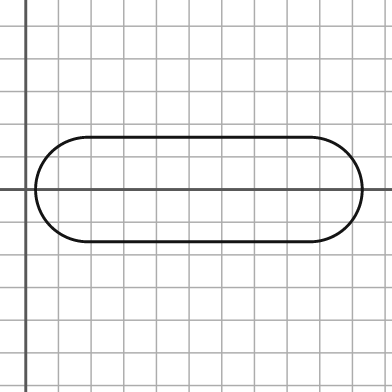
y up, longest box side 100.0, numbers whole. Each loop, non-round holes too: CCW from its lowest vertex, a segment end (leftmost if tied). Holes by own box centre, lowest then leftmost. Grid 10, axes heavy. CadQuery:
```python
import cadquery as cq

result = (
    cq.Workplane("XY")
    .moveTo(19.0, -16.0)
    .lineTo(87.0, -16.0)
    .threePointArc((103.0, 0.0), (87.0, 16.0))
    .lineTo(19.0, 16.0)
    .threePointArc((3.0, 0.0), (19.0, -16.0))
    .close()
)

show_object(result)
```